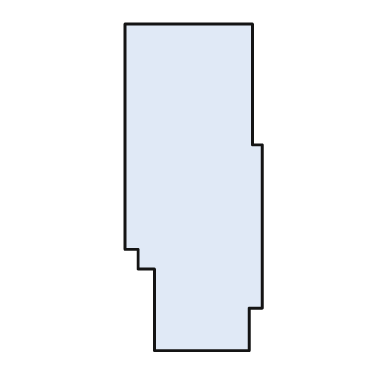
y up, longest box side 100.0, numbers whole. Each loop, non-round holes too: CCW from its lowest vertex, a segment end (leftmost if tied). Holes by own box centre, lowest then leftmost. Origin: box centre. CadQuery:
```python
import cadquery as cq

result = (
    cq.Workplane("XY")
    .moveTo(-12.0, -50.0)
    .lineTo(17.0, -50.0)
    .lineTo(17.0, -37.0)
    .lineTo(21.0, -37.0)
    .lineTo(21.0, 13.0)
    .lineTo(18.0, 13.0)
    .lineTo(18.0, 50.0)
    .lineTo(-21.0, 50.0)
    .lineTo(-21.0, -19.0)
    .lineTo(-17.0, -19.0)
    .lineTo(-17.0, -25.0)
    .lineTo(-12.0, -25.0)
    .close()
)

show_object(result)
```